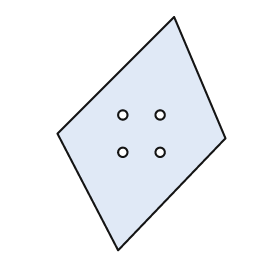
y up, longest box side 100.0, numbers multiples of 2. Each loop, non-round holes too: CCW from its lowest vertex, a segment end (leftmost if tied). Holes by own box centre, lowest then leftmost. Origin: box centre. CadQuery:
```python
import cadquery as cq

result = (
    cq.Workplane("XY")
    .moveTo(-10.0, -50.0)
    .lineTo(36.0, -2.0)
    .lineTo(14.0, 50.0)
    .lineTo(-36.0, 0.0)
    .close()
    .moveTo(-8.0, -8.0)
    .circle(2.0)
    .moveTo(8.0, -8.0)
    .circle(2.0)
    .moveTo(-8.0, 8.0)
    .circle(2.0)
    .moveTo(8.0, 8.0)
    .circle(2.0)
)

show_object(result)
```